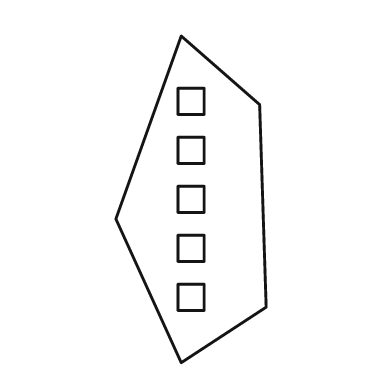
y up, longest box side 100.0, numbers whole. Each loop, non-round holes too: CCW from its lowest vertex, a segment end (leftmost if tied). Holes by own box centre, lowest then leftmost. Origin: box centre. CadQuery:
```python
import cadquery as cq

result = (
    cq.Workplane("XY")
    .moveTo(-3.0, -50.0)
    .lineTo(23.0, -33.0)
    .lineTo(21.0, 29.0)
    .lineTo(-3.0, 50.0)
    .lineTo(-23.0, -6.0)
    .close()
    .moveTo(-4.0, -34.0)
    .lineTo(4.0, -34.0)
    .lineTo(4.0, -26.0)
    .lineTo(-4.0, -26.0)
    .close()
    .moveTo(-4.0, -19.0)
    .lineTo(4.0, -19.0)
    .lineTo(4.0, -11.0)
    .lineTo(-4.0, -11.0)
    .close()
    .moveTo(-4.0, -4.0)
    .lineTo(4.0, -4.0)
    .lineTo(4.0, 4.0)
    .lineTo(-4.0, 4.0)
    .close()
    .moveTo(-4.0, 11.0)
    .lineTo(4.0, 11.0)
    .lineTo(4.0, 19.0)
    .lineTo(-4.0, 19.0)
    .close()
    .moveTo(-4.0, 26.0)
    .lineTo(4.0, 26.0)
    .lineTo(4.0, 34.0)
    .lineTo(-4.0, 34.0)
    .close()
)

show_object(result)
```